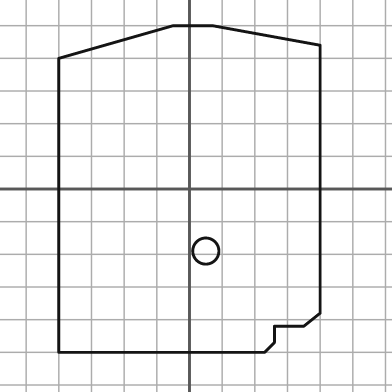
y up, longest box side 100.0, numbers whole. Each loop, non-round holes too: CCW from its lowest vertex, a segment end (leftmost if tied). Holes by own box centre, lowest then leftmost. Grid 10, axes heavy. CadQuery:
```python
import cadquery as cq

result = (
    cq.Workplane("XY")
    .moveTo(-40.0, -50.0)
    .lineTo(23.0, -50.0)
    .lineTo(26.0, -47.0)
    .lineTo(26.0, -42.0)
    .lineTo(35.0, -42.0)
    .lineTo(40.0, -38.0)
    .lineTo(40.0, 44.0)
    .lineTo(7.0, 50.0)
    .lineTo(-5.0, 50.0)
    .lineTo(-40.0, 40.0)
    .close()
    .moveTo(5.0, -19.0)
    .circle(4.0)
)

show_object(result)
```